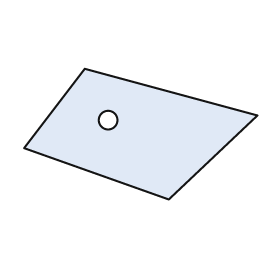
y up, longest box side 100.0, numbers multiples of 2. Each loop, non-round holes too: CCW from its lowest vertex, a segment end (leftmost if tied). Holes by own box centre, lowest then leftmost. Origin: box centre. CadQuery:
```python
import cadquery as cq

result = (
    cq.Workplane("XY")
    .moveTo(12.0, -28.0)
    .lineTo(50.0, 8.0)
    .lineTo(-24.0, 28.0)
    .lineTo(-50.0, -6.0)
    .close()
    .moveTo(-14.0, 6.0)
    .circle(4.0)
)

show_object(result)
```